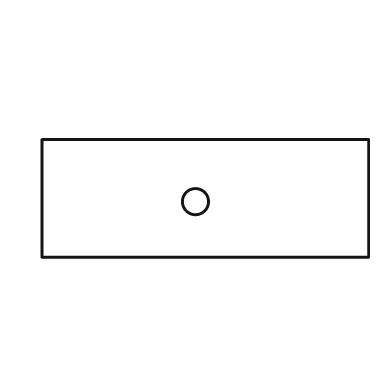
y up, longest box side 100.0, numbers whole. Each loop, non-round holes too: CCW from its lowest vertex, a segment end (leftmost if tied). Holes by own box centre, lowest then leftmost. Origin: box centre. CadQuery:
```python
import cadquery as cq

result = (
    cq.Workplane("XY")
    .moveTo(-50.0, -18.0)
    .lineTo(50.0, -18.0)
    .lineTo(50.0, 18.0)
    .lineTo(-50.0, 18.0)
    .close()
    .moveTo(-3.0, -1.0)
    .circle(4.0)
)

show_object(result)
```